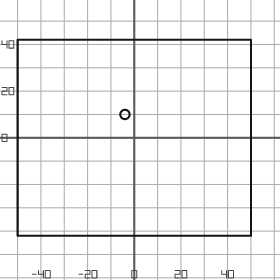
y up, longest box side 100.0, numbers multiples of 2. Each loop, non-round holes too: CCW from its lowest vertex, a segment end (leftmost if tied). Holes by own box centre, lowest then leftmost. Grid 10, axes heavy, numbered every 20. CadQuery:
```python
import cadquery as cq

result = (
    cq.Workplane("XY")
    .moveTo(-50.0, -42.0)
    .lineTo(50.0, -42.0)
    .lineTo(50.0, 42.0)
    .lineTo(-50.0, 42.0)
    .close()
    .moveTo(-4.0, 10.0)
    .circle(2.0)
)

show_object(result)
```